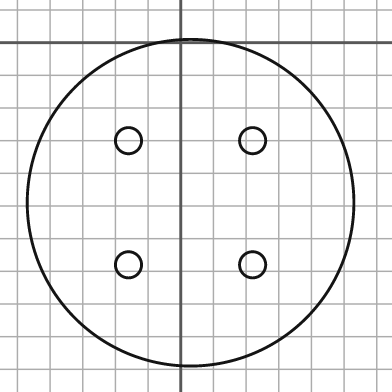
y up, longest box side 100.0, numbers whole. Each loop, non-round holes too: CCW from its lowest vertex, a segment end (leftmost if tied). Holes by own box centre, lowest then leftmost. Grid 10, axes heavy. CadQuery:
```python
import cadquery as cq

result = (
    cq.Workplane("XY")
    .moveTo(3.0, -49.0)
    .circle(50.0)
    .moveTo(-16.0, -68.0)
    .circle(4.0)
    .moveTo(22.0, -68.0)
    .circle(4.0)
    .moveTo(-16.0, -30.0)
    .circle(4.0)
    .moveTo(22.0, -30.0)
    .circle(4.0)
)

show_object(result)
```